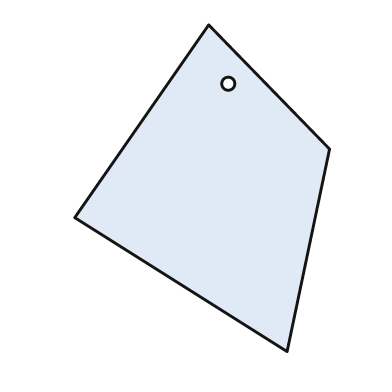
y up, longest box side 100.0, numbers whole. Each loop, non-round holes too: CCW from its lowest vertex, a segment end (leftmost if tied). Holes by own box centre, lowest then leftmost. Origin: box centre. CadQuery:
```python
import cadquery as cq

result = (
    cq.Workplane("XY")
    .moveTo(26.0, -50.0)
    .lineTo(39.0, 12.0)
    .lineTo(2.0, 50.0)
    .lineTo(-39.0, -9.0)
    .close()
    .moveTo(8.0, 32.0)
    .circle(2.0)
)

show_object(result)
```